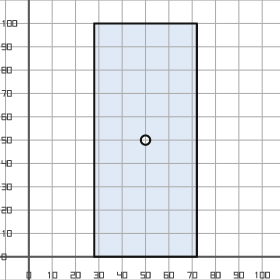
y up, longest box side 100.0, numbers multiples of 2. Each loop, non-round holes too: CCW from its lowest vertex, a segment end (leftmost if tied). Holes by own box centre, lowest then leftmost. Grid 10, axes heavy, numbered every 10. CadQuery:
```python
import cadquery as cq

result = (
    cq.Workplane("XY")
    .moveTo(28.0, 0.0)
    .lineTo(72.0, 0.0)
    .lineTo(72.0, 100.0)
    .lineTo(28.0, 100.0)
    .close()
    .moveTo(50.0, 50.0)
    .circle(2.0)
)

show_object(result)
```